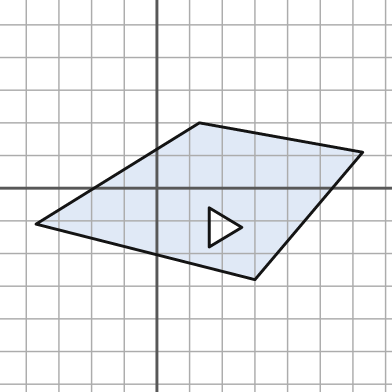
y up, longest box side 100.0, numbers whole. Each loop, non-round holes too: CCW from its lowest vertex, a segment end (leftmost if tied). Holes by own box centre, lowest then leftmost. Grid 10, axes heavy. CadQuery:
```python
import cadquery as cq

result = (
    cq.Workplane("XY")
    .moveTo(30.0, -28.0)
    .lineTo(63.0, 11.0)
    .lineTo(13.0, 20.0)
    .lineTo(-37.0, -11.0)
    .close()
    .moveTo(16.0, -18.0)
    .lineTo(26.0, -12.0)
    .lineTo(16.0, -6.0)
    .close()
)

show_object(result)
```